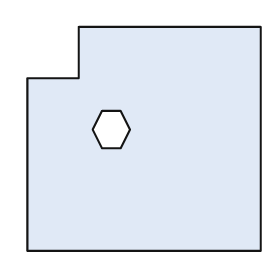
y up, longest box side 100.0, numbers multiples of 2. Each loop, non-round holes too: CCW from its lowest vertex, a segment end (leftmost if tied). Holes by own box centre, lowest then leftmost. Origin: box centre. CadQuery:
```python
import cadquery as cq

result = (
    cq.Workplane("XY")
    .moveTo(-50.0, -48.0)
    .lineTo(50.0, -48.0)
    .lineTo(50.0, 48.0)
    .lineTo(-28.0, 48.0)
    .lineTo(-28.0, 26.0)
    .lineTo(-50.0, 26.0)
    .close()
    .moveTo(-18.0, -4.0)
    .lineTo(-10.0, -4.0)
    .lineTo(-6.0, 4.0)
    .lineTo(-10.0, 12.0)
    .lineTo(-18.0, 12.0)
    .lineTo(-22.0, 4.0)
    .close()
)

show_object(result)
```